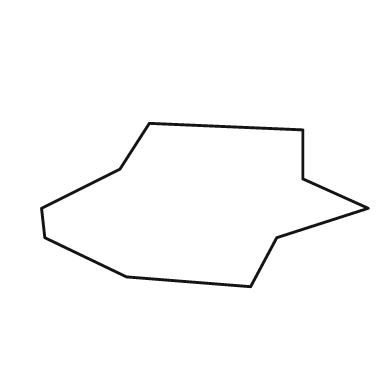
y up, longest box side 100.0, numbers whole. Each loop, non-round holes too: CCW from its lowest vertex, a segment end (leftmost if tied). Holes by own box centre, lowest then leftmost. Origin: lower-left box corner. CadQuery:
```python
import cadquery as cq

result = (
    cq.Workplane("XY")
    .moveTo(64.0, 0.0)
    .lineTo(72.0, 15.0)
    .lineTo(100.0, 24.0)
    .lineTo(80.0, 33.0)
    .lineTo(80.0, 48.0)
    .lineTo(33.0, 50.0)
    .lineTo(24.0, 36.0)
    .lineTo(0.0, 24.0)
    .lineTo(1.0, 15.0)
    .lineTo(26.0, 3.0)
    .close()
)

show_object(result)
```